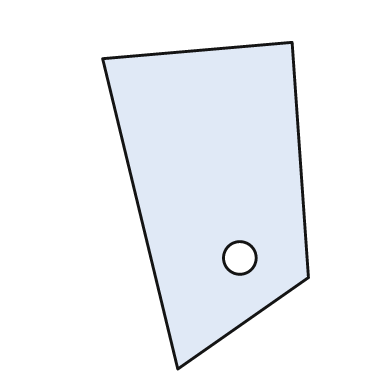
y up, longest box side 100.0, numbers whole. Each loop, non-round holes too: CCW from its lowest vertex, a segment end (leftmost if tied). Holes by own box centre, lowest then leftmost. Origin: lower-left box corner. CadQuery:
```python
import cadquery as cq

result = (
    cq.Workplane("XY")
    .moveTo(23.0, 0.0)
    .lineTo(63.0, 28.0)
    .lineTo(58.0, 100.0)
    .lineTo(0.0, 95.0)
    .close()
    .moveTo(42.0, 34.0)
    .circle(5.0)
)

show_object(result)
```